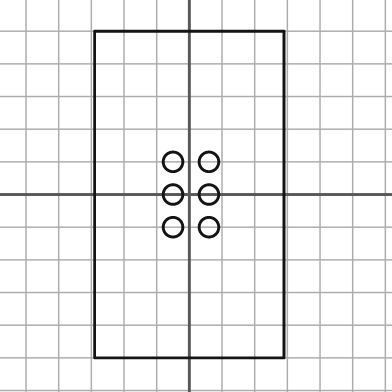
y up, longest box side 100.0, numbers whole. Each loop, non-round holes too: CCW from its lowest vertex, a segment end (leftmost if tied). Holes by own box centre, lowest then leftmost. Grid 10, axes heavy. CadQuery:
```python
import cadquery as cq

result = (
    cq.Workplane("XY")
    .moveTo(-29.0, -50.0)
    .lineTo(29.0, -50.0)
    .lineTo(29.0, 50.0)
    .lineTo(-29.0, 50.0)
    .close()
    .moveTo(-5.0, -10.0)
    .circle(3.0)
    .moveTo(6.0, -10.0)
    .circle(3.0)
    .moveTo(-5.0, 0.0)
    .circle(3.0)
    .moveTo(6.0, 0.0)
    .circle(3.0)
    .moveTo(-5.0, 10.0)
    .circle(3.0)
    .moveTo(6.0, 10.0)
    .circle(3.0)
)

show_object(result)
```